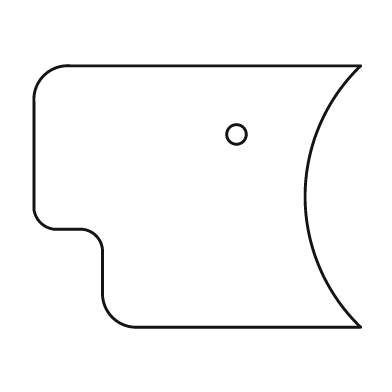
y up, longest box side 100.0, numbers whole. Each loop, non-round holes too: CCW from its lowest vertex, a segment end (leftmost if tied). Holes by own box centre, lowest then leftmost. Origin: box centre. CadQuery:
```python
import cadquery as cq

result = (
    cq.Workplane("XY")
    .moveTo(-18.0, -40.0)
    .lineTo(50.0, -40.0)
    .threePointArc((33.0, 0.0), (50.0, 40.0))
    .lineTo(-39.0, 40.0)
    .threePointArc((-47.0, 37.0), (-50.0, 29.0))
    .lineTo(-50.0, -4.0)
    .threePointArc((-48.0, -8.0), (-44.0, -10.0))
    .lineTo(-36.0, -10.0)
    .threePointArc((-31.0, -12.0), (-29.0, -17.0))
    .lineTo(-29.0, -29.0)
    .threePointArc((-26.0, -37.0), (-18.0, -40.0))
    .close()
    .moveTo(12.0, 19.0)
    .circle(3.0)
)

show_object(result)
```